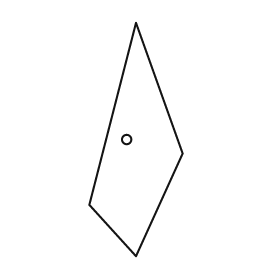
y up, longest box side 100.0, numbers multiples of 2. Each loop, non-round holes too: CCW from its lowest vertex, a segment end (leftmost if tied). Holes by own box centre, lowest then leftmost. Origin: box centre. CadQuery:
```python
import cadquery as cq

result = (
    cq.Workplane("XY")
    .moveTo(0.0, -50.0)
    .lineTo(20.0, -6.0)
    .lineTo(0.0, 50.0)
    .lineTo(-20.0, -28.0)
    .close()
    .moveTo(-4.0, 0.0)
    .circle(2.0)
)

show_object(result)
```